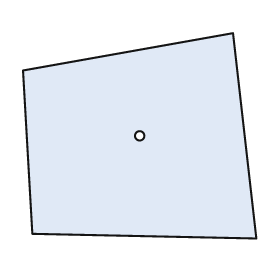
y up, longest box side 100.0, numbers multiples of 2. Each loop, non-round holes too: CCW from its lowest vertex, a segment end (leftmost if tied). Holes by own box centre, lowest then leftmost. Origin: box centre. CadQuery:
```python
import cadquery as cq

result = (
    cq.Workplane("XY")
    .moveTo(50.0, -44.0)
    .lineTo(40.0, 44.0)
    .lineTo(-50.0, 28.0)
    .lineTo(-46.0, -42.0)
    .close()
    .moveTo(0.0, 0.0)
    .circle(2.0)
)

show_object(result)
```